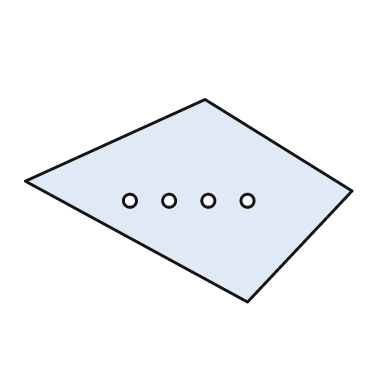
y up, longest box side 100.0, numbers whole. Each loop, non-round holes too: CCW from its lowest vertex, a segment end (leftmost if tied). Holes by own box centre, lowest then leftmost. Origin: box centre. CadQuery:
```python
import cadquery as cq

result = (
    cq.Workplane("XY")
    .moveTo(18.0, -31.0)
    .lineTo(50.0, 3.0)
    .lineTo(5.0, 31.0)
    .lineTo(-50.0, 6.0)
    .close()
    .moveTo(-18.0, 0.0)
    .circle(2.0)
    .moveTo(-6.0, 0.0)
    .circle(2.0)
    .moveTo(6.0, 0.0)
    .circle(2.0)
    .moveTo(18.0, 0.0)
    .circle(2.0)
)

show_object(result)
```